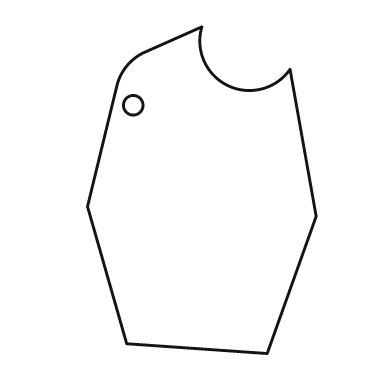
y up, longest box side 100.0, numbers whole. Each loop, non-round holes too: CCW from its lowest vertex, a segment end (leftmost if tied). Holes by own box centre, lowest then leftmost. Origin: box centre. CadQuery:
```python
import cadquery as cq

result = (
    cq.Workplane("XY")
    .moveTo(20.0, -50.0)
    .lineTo(35.0, -8.0)
    .lineTo(27.0, 37.0)
    .threePointArc((8.0, 32.0), (0.0, 50.0))
    .lineTo(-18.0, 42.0)
    .threePointArc((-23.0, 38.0), (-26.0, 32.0))
    .lineTo(-35.0, -5.0)
    .lineTo(-23.0, -47.0)
    .close()
    .moveTo(-21.0, 26.0)
    .circle(3.0)
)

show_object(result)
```